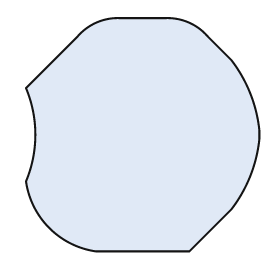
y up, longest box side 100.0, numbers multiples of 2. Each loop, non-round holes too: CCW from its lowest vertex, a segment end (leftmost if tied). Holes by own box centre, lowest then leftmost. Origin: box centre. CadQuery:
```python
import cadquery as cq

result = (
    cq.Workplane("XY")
    .moveTo(-20.0, -50.0)
    .lineTo(20.0, -50.0)
    .lineTo(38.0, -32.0)
    .threePointArc((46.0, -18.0), (50.0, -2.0))
    .lineTo(50.0, 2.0)
    .threePointArc((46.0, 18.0), (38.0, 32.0))
    .lineTo(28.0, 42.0)
    .threePointArc((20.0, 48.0), (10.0, 50.0))
    .lineTo(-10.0, 50.0)
    .threePointArc((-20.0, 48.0), (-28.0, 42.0))
    .lineTo(-50.0, 20.0)
    .threePointArc((-46.0, 0.0), (-50.0, -20.0))
    .threePointArc((-40.0, -40.0), (-20.0, -50.0))
    .close()
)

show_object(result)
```